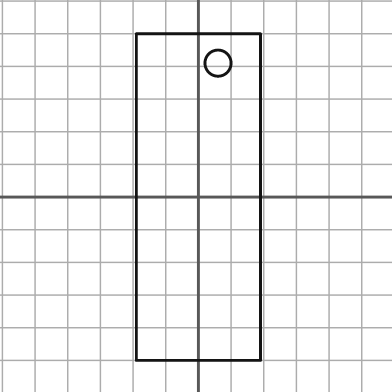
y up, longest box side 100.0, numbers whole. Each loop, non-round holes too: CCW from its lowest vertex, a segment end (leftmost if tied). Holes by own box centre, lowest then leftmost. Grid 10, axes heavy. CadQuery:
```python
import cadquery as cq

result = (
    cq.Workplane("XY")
    .moveTo(-19.0, -50.0)
    .lineTo(19.0, -50.0)
    .lineTo(19.0, 50.0)
    .lineTo(-19.0, 50.0)
    .close()
    .moveTo(6.0, 41.0)
    .circle(4.0)
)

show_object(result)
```